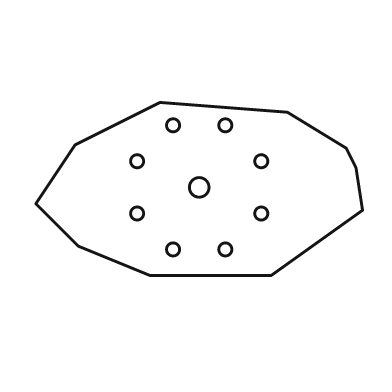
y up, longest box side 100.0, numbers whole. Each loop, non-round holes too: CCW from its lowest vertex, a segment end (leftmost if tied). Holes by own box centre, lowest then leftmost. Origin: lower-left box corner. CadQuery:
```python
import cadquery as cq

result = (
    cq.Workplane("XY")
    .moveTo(35.0, 0.0)
    .lineTo(72.0, 0.0)
    .lineTo(100.0, 20.0)
    .lineTo(98.0, 33.0)
    .lineTo(95.0, 39.0)
    .lineTo(77.0, 50.0)
    .lineTo(38.0, 53.0)
    .lineTo(12.0, 40.0)
    .lineTo(0.0, 22.0)
    .lineTo(13.0, 9.0)
    .close()
    .moveTo(42.0, 8.0)
    .circle(2.0)
    .moveTo(58.0, 8.0)
    .circle(2.0)
    .moveTo(31.0, 19.0)
    .circle(2.0)
    .moveTo(69.0, 19.0)
    .circle(2.0)
    .moveTo(50.0, 27.0)
    .circle(3.0)
    .moveTo(31.0, 35.0)
    .circle(2.0)
    .moveTo(69.0, 35.0)
    .circle(2.0)
    .moveTo(42.0, 46.0)
    .circle(2.0)
    .moveTo(58.0, 46.0)
    .circle(2.0)
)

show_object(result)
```